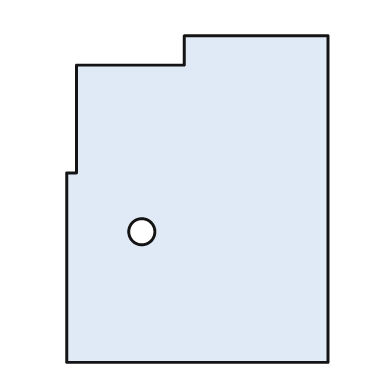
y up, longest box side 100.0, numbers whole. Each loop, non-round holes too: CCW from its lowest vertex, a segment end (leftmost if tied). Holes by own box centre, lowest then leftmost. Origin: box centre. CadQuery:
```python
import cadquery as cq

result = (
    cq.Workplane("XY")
    .moveTo(-40.0, -50.0)
    .lineTo(40.0, -50.0)
    .lineTo(40.0, 50.0)
    .lineTo(-4.0, 50.0)
    .lineTo(-4.0, 41.0)
    .lineTo(-37.0, 41.0)
    .lineTo(-37.0, 8.0)
    .lineTo(-40.0, 8.0)
    .close()
    .moveTo(-17.0, -10.0)
    .circle(4.0)
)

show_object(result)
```